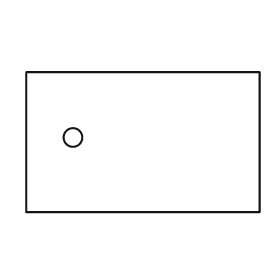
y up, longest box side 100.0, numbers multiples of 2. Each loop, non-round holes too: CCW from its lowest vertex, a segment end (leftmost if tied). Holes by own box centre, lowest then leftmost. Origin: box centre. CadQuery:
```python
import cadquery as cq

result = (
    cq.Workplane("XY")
    .moveTo(-50.0, -30.0)
    .lineTo(50.0, -30.0)
    .lineTo(50.0, 30.0)
    .lineTo(-50.0, 30.0)
    .close()
    .moveTo(-30.0, 2.0)
    .circle(4.0)
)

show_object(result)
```